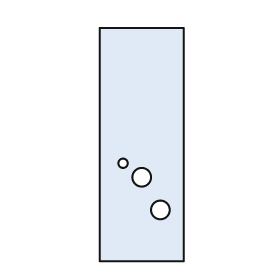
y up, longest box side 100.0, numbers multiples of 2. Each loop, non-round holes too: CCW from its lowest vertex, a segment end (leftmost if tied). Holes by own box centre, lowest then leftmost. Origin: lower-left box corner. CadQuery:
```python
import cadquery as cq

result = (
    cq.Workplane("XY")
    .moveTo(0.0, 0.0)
    .lineTo(36.0, 0.0)
    .lineTo(36.0, 100.0)
    .lineTo(0.0, 100.0)
    .close()
    .moveTo(26.0, 22.0)
    .circle(4.0)
    .moveTo(18.0, 36.0)
    .circle(4.0)
    .moveTo(10.0, 42.0)
    .circle(2.0)
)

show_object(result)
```